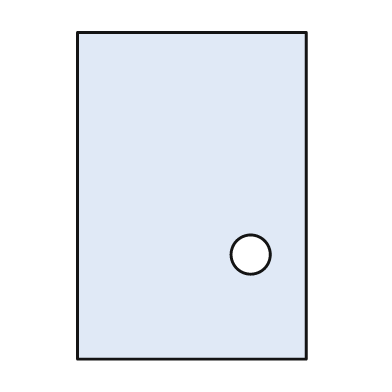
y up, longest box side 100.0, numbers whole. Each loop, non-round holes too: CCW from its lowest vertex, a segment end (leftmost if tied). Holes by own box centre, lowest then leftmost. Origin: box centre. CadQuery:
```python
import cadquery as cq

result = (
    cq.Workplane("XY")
    .moveTo(-35.0, -50.0)
    .lineTo(35.0, -50.0)
    .lineTo(35.0, 50.0)
    .lineTo(-35.0, 50.0)
    .close()
    .moveTo(18.0, -18.0)
    .circle(6.0)
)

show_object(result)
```